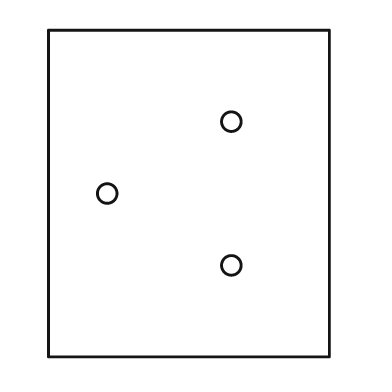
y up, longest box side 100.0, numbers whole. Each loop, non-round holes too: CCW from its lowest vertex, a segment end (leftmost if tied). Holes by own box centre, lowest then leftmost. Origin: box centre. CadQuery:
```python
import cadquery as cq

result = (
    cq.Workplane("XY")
    .moveTo(-43.0, -50.0)
    .lineTo(43.0, -50.0)
    .lineTo(43.0, 50.0)
    .lineTo(-43.0, 50.0)
    .close()
    .moveTo(13.0, -22.0)
    .circle(3.0)
    .moveTo(-25.0, 0.0)
    .circle(3.0)
    .moveTo(13.0, 22.0)
    .circle(3.0)
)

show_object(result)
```